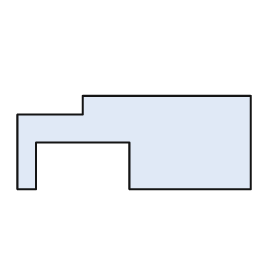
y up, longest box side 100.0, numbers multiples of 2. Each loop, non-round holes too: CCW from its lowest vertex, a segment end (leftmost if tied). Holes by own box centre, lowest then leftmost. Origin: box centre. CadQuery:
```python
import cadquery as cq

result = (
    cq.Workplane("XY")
    .moveTo(-50.0, -20.0)
    .lineTo(-42.0, -20.0)
    .lineTo(-42.0, 0.0)
    .lineTo(-2.0, 0.0)
    .lineTo(-2.0, -20.0)
    .lineTo(50.0, -20.0)
    .lineTo(50.0, 20.0)
    .lineTo(-22.0, 20.0)
    .lineTo(-22.0, 12.0)
    .lineTo(-50.0, 12.0)
    .close()
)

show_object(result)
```